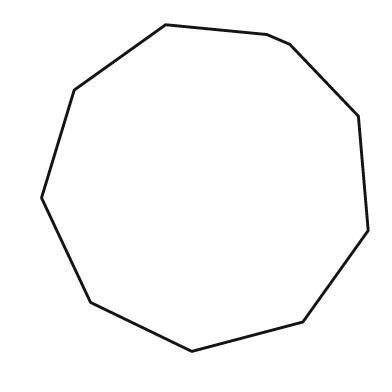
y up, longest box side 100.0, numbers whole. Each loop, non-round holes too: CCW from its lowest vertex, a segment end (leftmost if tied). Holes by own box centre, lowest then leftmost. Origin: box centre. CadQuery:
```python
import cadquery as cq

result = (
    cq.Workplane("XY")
    .moveTo(-4.0, -50.0)
    .lineTo(30.0, -41.0)
    .lineTo(50.0, -13.0)
    .lineTo(47.0, 22.0)
    .lineTo(26.0, 44.0)
    .lineTo(19.0, 47.0)
    .lineTo(-12.0, 50.0)
    .lineTo(-40.0, 30.0)
    .lineTo(-50.0, -3.0)
    .lineTo(-35.0, -35.0)
    .close()
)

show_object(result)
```